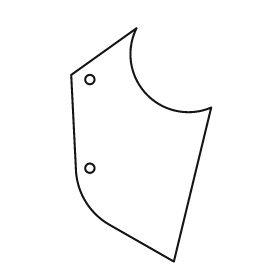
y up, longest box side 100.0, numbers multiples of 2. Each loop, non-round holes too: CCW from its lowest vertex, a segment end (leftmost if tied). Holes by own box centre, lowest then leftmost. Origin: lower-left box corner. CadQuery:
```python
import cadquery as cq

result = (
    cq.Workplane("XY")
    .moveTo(44.0, 0.0)
    .lineTo(60.0, 66.0)
    .threePointArc((32.0, 72.0), (28.0, 100.0))
    .lineTo(0.0, 80.0)
    .lineTo(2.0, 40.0)
    .threePointArc((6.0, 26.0), (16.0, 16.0))
    .close()
    .moveTo(8.0, 40.0)
    .circle(2.0)
    .moveTo(8.0, 78.0)
    .circle(2.0)
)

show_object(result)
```